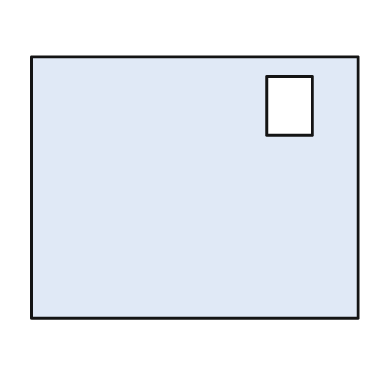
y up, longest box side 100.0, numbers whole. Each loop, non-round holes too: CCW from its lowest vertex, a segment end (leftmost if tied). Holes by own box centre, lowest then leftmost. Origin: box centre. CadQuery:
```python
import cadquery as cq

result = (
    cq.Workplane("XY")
    .moveTo(-50.0, -40.0)
    .lineTo(50.0, -40.0)
    .lineTo(50.0, 40.0)
    .lineTo(-50.0, 40.0)
    .close()
    .moveTo(22.0, 16.0)
    .lineTo(36.0, 16.0)
    .lineTo(36.0, 34.0)
    .lineTo(22.0, 34.0)
    .close()
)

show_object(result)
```